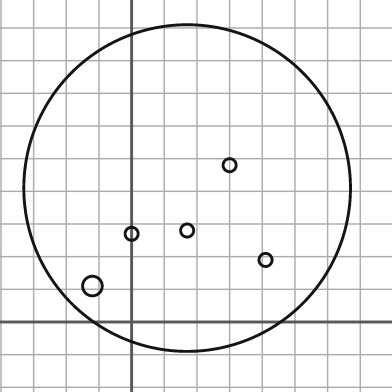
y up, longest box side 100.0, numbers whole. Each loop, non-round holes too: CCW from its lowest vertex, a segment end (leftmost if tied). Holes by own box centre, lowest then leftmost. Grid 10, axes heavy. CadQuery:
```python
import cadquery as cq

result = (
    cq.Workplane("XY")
    .moveTo(17.0, 41.0)
    .circle(50.0)
    .moveTo(-12.0, 11.0)
    .circle(3.0)
    .moveTo(41.0, 19.0)
    .circle(2.0)
    .moveTo(0.0, 27.0)
    .circle(2.0)
    .moveTo(17.0, 28.0)
    .circle(2.0)
    .moveTo(30.0, 48.0)
    .circle(2.0)
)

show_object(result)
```